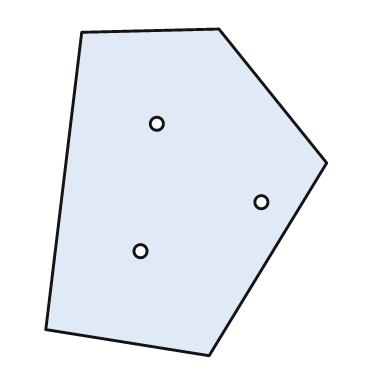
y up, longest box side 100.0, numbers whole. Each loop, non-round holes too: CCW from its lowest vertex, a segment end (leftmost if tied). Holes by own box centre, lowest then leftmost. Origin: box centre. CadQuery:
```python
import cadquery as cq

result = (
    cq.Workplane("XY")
    .moveTo(7.0, -50.0)
    .lineTo(43.0, 9.0)
    .lineTo(10.0, 50.0)
    .lineTo(-32.0, 49.0)
    .lineTo(-43.0, -42.0)
    .close()
    .moveTo(-14.0, -18.0)
    .circle(2.0)
    .moveTo(23.0, -3.0)
    .circle(2.0)
    .moveTo(-9.0, 21.0)
    .circle(2.0)
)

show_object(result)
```